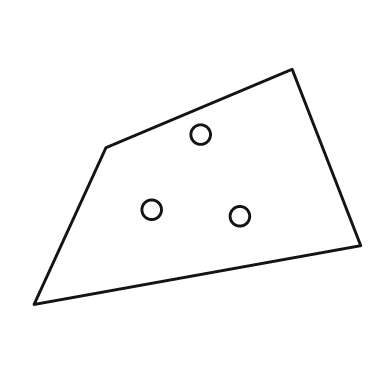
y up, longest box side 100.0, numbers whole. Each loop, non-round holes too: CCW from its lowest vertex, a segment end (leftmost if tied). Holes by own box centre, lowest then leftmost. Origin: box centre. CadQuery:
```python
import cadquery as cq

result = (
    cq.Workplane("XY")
    .moveTo(-50.0, -36.0)
    .lineTo(50.0, -18.0)
    .lineTo(29.0, 36.0)
    .lineTo(-28.0, 12.0)
    .close()
    .moveTo(13.0, -9.0)
    .circle(3.0)
    .moveTo(-14.0, -7.0)
    .circle(3.0)
    .moveTo(1.0, 16.0)
    .circle(3.0)
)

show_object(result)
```